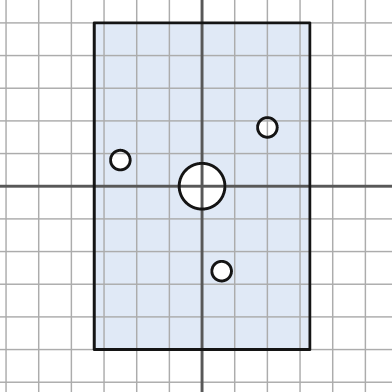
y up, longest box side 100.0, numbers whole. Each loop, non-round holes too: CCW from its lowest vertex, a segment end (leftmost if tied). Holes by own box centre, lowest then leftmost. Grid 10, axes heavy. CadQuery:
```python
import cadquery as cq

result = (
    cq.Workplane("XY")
    .moveTo(-33.0, -50.0)
    .lineTo(33.0, -50.0)
    .lineTo(33.0, 50.0)
    .lineTo(-33.0, 50.0)
    .close()
    .moveTo(6.0, -26.0)
    .circle(3.0)
    .moveTo(0.0, 0.0)
    .circle(7.0)
    .moveTo(-25.0, 8.0)
    .circle(3.0)
    .moveTo(20.0, 18.0)
    .circle(3.0)
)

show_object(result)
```